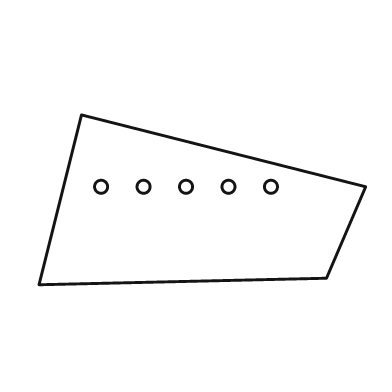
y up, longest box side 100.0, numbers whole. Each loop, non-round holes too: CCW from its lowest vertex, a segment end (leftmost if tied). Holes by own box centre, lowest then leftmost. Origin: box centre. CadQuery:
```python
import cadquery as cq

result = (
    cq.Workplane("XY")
    .moveTo(-50.0, -26.0)
    .lineTo(38.0, -24.0)
    .lineTo(50.0, 4.0)
    .lineTo(-37.0, 26.0)
    .close()
    .moveTo(-31.0, 4.0)
    .circle(2.0)
    .moveTo(-18.0, 4.0)
    .circle(2.0)
    .moveTo(-5.0, 4.0)
    .circle(2.0)
    .moveTo(8.0, 4.0)
    .circle(2.0)
    .moveTo(21.0, 4.0)
    .circle(2.0)
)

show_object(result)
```